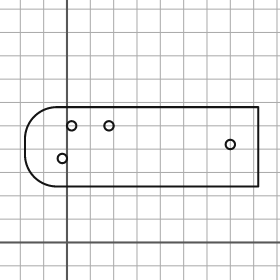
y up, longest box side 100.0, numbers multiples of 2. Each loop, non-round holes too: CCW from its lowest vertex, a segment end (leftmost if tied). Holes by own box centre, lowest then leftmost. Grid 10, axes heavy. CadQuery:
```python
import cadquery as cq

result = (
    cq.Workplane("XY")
    .moveTo(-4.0, 24.0)
    .lineTo(82.0, 24.0)
    .lineTo(82.0, 58.0)
    .lineTo(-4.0, 58.0)
    .threePointArc((-14.0, 54.0), (-18.0, 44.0))
    .lineTo(-18.0, 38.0)
    .threePointArc((-14.0, 28.0), (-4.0, 24.0))
    .close()
    .moveTo(-2.0, 36.0)
    .circle(2.0)
    .moveTo(70.0, 42.0)
    .circle(2.0)
    .moveTo(2.0, 50.0)
    .circle(2.0)
    .moveTo(18.0, 50.0)
    .circle(2.0)
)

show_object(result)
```